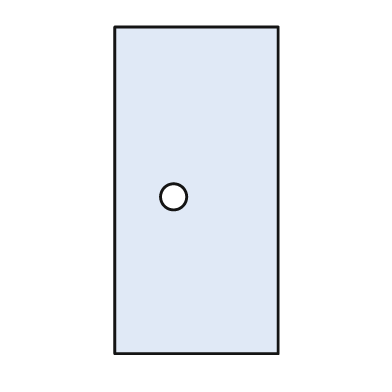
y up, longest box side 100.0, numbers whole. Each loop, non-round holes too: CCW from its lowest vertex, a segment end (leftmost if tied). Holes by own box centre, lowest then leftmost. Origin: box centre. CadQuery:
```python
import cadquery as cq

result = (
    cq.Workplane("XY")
    .moveTo(-25.0, -50.0)
    .lineTo(25.0, -50.0)
    .lineTo(25.0, 50.0)
    .lineTo(-25.0, 50.0)
    .close()
    .moveTo(-7.0, -2.0)
    .circle(4.0)
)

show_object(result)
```